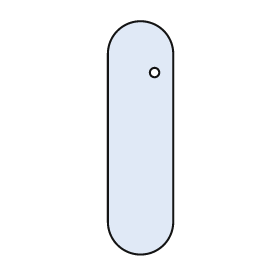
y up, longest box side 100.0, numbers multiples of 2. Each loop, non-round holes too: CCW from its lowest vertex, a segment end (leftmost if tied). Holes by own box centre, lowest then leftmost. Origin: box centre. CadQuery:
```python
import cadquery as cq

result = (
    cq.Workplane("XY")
    .moveTo(-14.0, -36.0)
    .threePointArc((0.0, -50.0), (14.0, -36.0))
    .lineTo(14.0, 36.0)
    .threePointArc((0.0, 50.0), (-14.0, 36.0))
    .close()
    .moveTo(6.0, 28.0)
    .circle(2.0)
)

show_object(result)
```